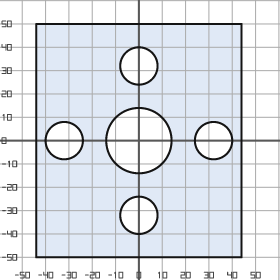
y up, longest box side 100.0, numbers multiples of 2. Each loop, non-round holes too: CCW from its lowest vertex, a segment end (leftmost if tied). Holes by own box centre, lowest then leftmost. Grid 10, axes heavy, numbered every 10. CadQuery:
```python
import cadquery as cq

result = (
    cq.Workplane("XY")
    .moveTo(-44.0, -50.0)
    .lineTo(44.0, -50.0)
    .lineTo(44.0, 50.0)
    .lineTo(-44.0, 50.0)
    .close()
    .moveTo(0.0, -32.0)
    .circle(8.0)
    .moveTo(-32.0, 0.0)
    .circle(8.0)
    .moveTo(0.0, 0.0)
    .circle(14.0)
    .moveTo(32.0, 0.0)
    .circle(8.0)
    .moveTo(0.0, 32.0)
    .circle(8.0)
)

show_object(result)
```